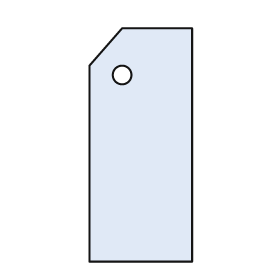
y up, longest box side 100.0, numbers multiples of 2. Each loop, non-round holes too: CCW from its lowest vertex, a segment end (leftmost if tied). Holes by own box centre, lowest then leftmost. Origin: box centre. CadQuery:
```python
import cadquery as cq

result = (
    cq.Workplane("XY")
    .moveTo(-22.0, -50.0)
    .lineTo(22.0, -50.0)
    .lineTo(22.0, 50.0)
    .lineTo(-8.0, 50.0)
    .lineTo(-22.0, 34.0)
    .close()
    .moveTo(-8.0, 30.0)
    .circle(4.0)
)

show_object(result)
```